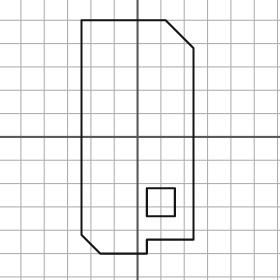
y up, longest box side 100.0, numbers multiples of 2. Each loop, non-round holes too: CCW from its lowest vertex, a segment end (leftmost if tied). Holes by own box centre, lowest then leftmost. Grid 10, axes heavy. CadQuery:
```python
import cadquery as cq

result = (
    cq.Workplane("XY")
    .moveTo(-16.0, -50.0)
    .lineTo(4.0, -50.0)
    .lineTo(4.0, -44.0)
    .lineTo(24.0, -44.0)
    .lineTo(24.0, 38.0)
    .lineTo(12.0, 50.0)
    .lineTo(-24.0, 50.0)
    .lineTo(-24.0, -42.0)
    .close()
    .moveTo(4.0, -34.0)
    .lineTo(16.0, -34.0)
    .lineTo(16.0, -22.0)
    .lineTo(4.0, -22.0)
    .close()
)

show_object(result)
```